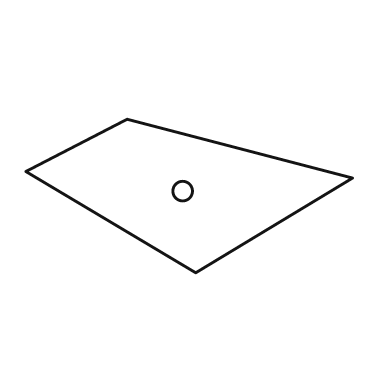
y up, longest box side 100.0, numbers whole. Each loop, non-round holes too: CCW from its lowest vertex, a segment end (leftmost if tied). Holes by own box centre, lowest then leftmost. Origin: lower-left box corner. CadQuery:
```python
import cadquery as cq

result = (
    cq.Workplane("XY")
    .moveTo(52.0, 0.0)
    .lineTo(100.0, 29.0)
    .lineTo(31.0, 47.0)
    .lineTo(0.0, 31.0)
    .close()
    .moveTo(48.0, 25.0)
    .circle(3.0)
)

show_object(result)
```